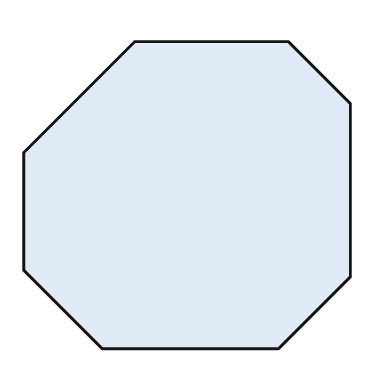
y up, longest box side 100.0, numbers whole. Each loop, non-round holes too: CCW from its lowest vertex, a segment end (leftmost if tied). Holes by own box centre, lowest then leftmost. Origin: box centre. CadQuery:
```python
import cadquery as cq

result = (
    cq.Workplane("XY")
    .moveTo(-26.0, -47.0)
    .lineTo(28.0, -47.0)
    .lineTo(50.0, -25.0)
    .lineTo(50.0, 28.0)
    .lineTo(31.0, 47.0)
    .lineTo(-16.0, 47.0)
    .lineTo(-50.0, 13.0)
    .lineTo(-50.0, -23.0)
    .close()
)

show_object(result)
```